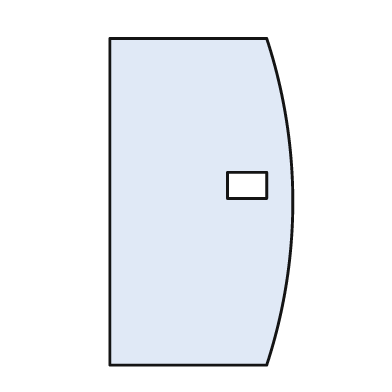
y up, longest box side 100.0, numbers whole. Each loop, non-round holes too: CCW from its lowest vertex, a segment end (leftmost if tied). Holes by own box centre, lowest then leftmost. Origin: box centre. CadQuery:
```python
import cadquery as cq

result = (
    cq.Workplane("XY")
    .moveTo(-28.0, -50.0)
    .lineTo(20.0, -50.0)
    .threePointArc((28.0, 0.0), (20.0, 50.0))
    .lineTo(-28.0, 50.0)
    .close()
    .moveTo(8.0, 1.0)
    .lineTo(20.0, 1.0)
    .lineTo(20.0, 9.0)
    .lineTo(8.0, 9.0)
    .close()
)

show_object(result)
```